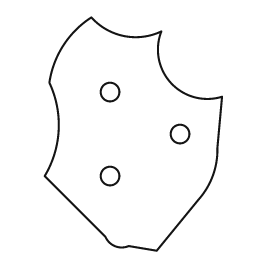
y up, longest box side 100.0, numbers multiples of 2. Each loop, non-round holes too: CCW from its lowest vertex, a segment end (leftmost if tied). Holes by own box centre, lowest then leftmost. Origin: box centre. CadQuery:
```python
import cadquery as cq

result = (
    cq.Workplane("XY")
    .moveTo(10.0, -50.0)
    .lineTo(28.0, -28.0)
    .threePointArc((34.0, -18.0), (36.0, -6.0))
    .lineTo(38.0, 16.0)
    .threePointArc((16.0, 22.0), (12.0, 44.0))
    .threePointArc((-4.0, 42.0), (-18.0, 50.0))
    .threePointArc((-30.0, 38.0), (-36.0, 22.0))
    .threePointArc((-32.0, 2.0), (-38.0, -18.0))
    .lineTo(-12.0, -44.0)
    .threePointArc((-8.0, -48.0), (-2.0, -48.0))
    .close()
    .moveTo(-10.0, -18.0)
    .circle(4.0)
    .moveTo(20.0, 0.0)
    .circle(4.0)
    .moveTo(-10.0, 18.0)
    .circle(4.0)
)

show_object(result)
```